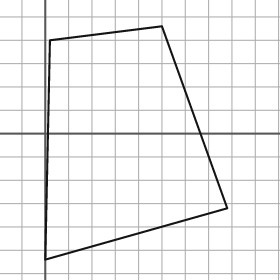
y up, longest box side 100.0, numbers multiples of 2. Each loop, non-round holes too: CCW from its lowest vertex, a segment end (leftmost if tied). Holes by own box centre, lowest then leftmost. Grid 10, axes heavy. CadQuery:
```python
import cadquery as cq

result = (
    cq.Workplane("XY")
    .moveTo(0.0, -54.0)
    .lineTo(78.0, -32.0)
    .lineTo(50.0, 46.0)
    .lineTo(2.0, 40.0)
    .close()
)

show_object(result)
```